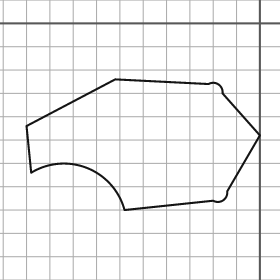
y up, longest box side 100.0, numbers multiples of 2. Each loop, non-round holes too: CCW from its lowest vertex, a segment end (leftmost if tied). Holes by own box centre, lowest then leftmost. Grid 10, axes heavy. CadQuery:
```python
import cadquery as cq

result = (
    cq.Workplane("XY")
    .moveTo(-58.0, -80.0)
    .lineTo(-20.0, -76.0)
    .threePointArc((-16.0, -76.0), (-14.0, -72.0))
    .lineTo(0.0, -48.0)
    .lineTo(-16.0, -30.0)
    .threePointArc((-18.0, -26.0), (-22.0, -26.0))
    .lineTo(-62.0, -24.0)
    .lineTo(-100.0, -44.0)
    .lineTo(-98.0, -64.0)
    .threePointArc((-74.0, -62.0), (-58.0, -80.0))
    .close()
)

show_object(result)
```